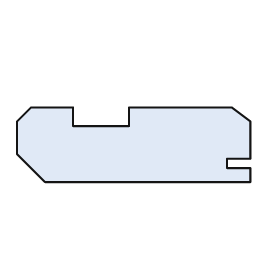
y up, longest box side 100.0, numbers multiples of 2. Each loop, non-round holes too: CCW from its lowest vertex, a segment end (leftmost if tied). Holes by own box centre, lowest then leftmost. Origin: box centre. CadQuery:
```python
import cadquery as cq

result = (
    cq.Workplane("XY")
    .moveTo(-38.0, -16.0)
    .lineTo(50.0, -16.0)
    .lineTo(50.0, -10.0)
    .lineTo(40.0, -10.0)
    .lineTo(40.0, -6.0)
    .lineTo(50.0, -6.0)
    .lineTo(50.0, 10.0)
    .lineTo(42.0, 16.0)
    .lineTo(-2.0, 16.0)
    .lineTo(-2.0, 8.0)
    .lineTo(-26.0, 8.0)
    .lineTo(-26.0, 16.0)
    .lineTo(-44.0, 16.0)
    .lineTo(-50.0, 10.0)
    .lineTo(-50.0, -4.0)
    .close()
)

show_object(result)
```